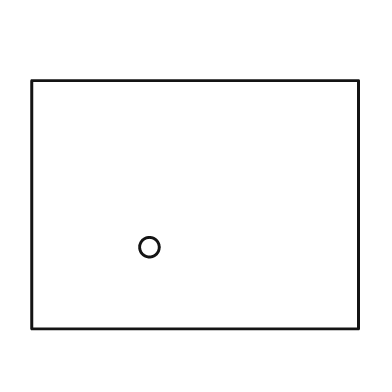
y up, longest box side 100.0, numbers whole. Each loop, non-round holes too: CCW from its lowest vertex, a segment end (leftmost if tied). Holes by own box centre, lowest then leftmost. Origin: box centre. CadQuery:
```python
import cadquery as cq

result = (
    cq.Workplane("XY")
    .moveTo(-50.0, -38.0)
    .lineTo(50.0, -38.0)
    .lineTo(50.0, 38.0)
    .lineTo(-50.0, 38.0)
    .close()
    .moveTo(-14.0, -13.0)
    .circle(3.0)
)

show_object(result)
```